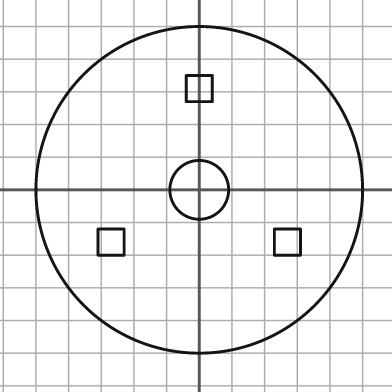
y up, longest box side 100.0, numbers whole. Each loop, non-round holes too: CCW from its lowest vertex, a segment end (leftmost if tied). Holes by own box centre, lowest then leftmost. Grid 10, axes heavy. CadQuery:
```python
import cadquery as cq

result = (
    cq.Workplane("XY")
    .moveTo(0.0, 0.0)
    .circle(50.0)
    .moveTo(-31.0, -20.0)
    .lineTo(-23.0, -20.0)
    .lineTo(-23.0, -12.0)
    .lineTo(-31.0, -12.0)
    .close()
    .moveTo(23.0, -20.0)
    .lineTo(31.0, -20.0)
    .lineTo(31.0, -12.0)
    .lineTo(23.0, -12.0)
    .close()
    .moveTo(0.0, 0.0)
    .circle(9.0)
    .moveTo(-4.0, 27.0)
    .lineTo(4.0, 27.0)
    .lineTo(4.0, 35.0)
    .lineTo(-4.0, 35.0)
    .close()
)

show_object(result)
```